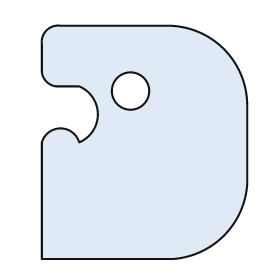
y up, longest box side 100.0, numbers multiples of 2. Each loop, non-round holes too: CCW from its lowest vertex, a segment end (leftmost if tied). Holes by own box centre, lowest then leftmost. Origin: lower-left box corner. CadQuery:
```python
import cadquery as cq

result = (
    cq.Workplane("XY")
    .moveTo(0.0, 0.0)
    .lineTo(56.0, 0.0)
    .threePointArc((78.0, 10.0), (88.0, 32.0))
    .lineTo(88.0, 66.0)
    .threePointArc((78.0, 90.0), (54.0, 100.0))
    .lineTo(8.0, 100.0)
    .threePointArc((2.0, 98.0), (0.0, 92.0))
    .lineTo(0.0, 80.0)
    .threePointArc((2.0, 76.0), (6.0, 74.0))
    .lineTo(16.0, 74.0)
    .threePointArc((24.0, 62.0), (16.0, 50.0))
    .threePointArc((8.0, 56.0), (0.0, 50.0))
    .close()
    .moveTo(38.0, 72.0)
    .circle(8.0)
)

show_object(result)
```